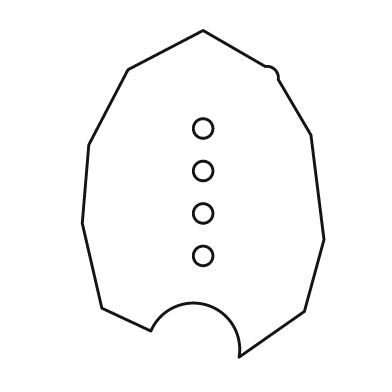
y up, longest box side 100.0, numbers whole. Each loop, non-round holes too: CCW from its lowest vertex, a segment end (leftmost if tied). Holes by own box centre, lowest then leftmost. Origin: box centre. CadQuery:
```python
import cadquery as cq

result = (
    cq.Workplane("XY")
    .moveTo(11.0, -50.0)
    .lineTo(31.0, -36.0)
    .lineTo(37.0, -14.0)
    .lineTo(33.0, 18.0)
    .lineTo(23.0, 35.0)
    .threePointArc((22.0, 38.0), (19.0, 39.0))
    .lineTo(0.0, 50.0)
    .lineTo(-23.0, 38.0)
    .lineTo(-35.0, 15.0)
    .lineTo(-37.0, -9.0)
    .lineTo(-31.0, -35.0)
    .lineTo(-16.0, -42.0)
    .threePointArc((1.0, -34.0), (11.0, -50.0))
    .close()
    .moveTo(0.0, -19.0)
    .circle(3.0)
    .moveTo(0.0, -6.0)
    .circle(3.0)
    .moveTo(0.0, 7.0)
    .circle(3.0)
    .moveTo(0.0, 20.0)
    .circle(3.0)
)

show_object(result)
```